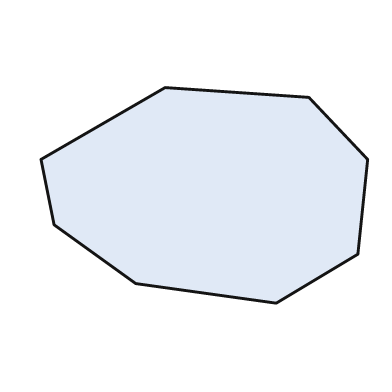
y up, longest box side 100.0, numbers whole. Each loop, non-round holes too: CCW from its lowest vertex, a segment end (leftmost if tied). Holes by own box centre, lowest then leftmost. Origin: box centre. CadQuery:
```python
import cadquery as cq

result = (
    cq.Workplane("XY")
    .moveTo(22.0, -33.0)
    .lineTo(47.0, -18.0)
    .lineTo(50.0, 11.0)
    .lineTo(32.0, 30.0)
    .lineTo(-12.0, 33.0)
    .lineTo(-50.0, 11.0)
    .lineTo(-46.0, -9.0)
    .lineTo(-21.0, -27.0)
    .close()
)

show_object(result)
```